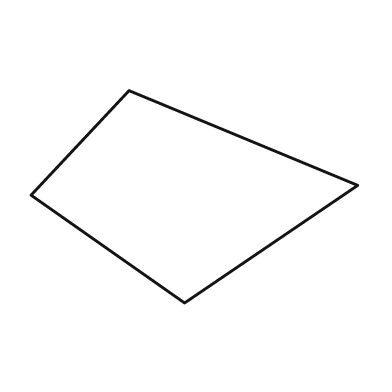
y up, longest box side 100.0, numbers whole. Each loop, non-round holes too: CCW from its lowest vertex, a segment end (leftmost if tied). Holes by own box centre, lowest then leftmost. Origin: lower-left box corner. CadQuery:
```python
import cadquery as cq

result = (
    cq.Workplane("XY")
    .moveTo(47.0, 0.0)
    .lineTo(100.0, 36.0)
    .lineTo(30.0, 65.0)
    .lineTo(0.0, 33.0)
    .close()
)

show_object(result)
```